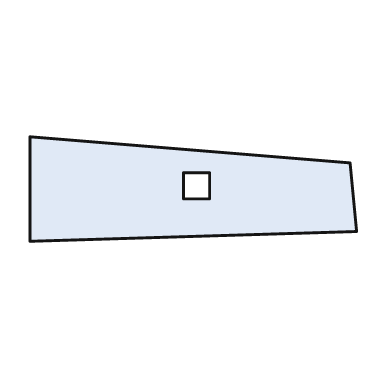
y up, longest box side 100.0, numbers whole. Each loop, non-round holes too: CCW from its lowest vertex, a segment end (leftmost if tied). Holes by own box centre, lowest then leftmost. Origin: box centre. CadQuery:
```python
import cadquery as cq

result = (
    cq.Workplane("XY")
    .moveTo(-50.0, -16.0)
    .lineTo(50.0, -13.0)
    .lineTo(48.0, 8.0)
    .lineTo(-50.0, 16.0)
    .close()
    .moveTo(-3.0, -3.0)
    .lineTo(5.0, -3.0)
    .lineTo(5.0, 5.0)
    .lineTo(-3.0, 5.0)
    .close()
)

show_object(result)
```